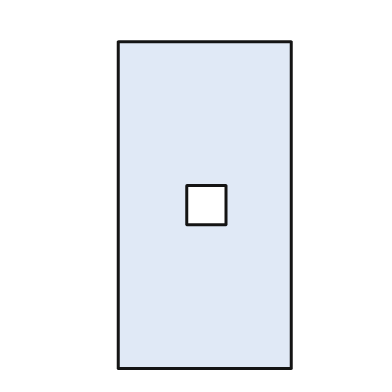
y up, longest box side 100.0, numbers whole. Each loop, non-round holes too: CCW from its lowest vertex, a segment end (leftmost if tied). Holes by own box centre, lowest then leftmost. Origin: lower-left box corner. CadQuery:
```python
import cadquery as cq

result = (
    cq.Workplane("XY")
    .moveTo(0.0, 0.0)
    .lineTo(53.0, 0.0)
    .lineTo(53.0, 100.0)
    .lineTo(0.0, 100.0)
    .close()
    .moveTo(21.0, 44.0)
    .lineTo(33.0, 44.0)
    .lineTo(33.0, 56.0)
    .lineTo(21.0, 56.0)
    .close()
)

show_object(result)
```